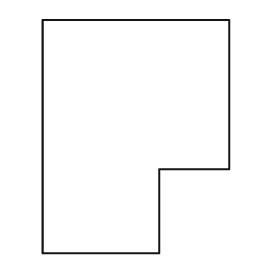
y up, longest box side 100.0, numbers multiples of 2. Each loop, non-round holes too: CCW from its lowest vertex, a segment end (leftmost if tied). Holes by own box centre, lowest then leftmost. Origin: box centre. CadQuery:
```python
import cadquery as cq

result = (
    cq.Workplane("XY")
    .moveTo(-40.0, -50.0)
    .lineTo(10.0, -50.0)
    .lineTo(10.0, -14.0)
    .lineTo(40.0, -14.0)
    .lineTo(40.0, 50.0)
    .lineTo(-40.0, 50.0)
    .close()
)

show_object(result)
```